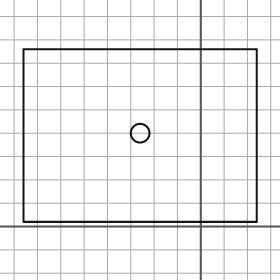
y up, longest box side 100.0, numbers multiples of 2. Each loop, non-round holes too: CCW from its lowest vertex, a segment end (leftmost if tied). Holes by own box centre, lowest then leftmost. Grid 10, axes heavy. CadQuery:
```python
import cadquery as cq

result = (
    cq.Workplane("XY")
    .moveTo(-76.0, 2.0)
    .lineTo(24.0, 2.0)
    .lineTo(24.0, 76.0)
    .lineTo(-76.0, 76.0)
    .close()
    .moveTo(-26.0, 40.0)
    .circle(4.0)
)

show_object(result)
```